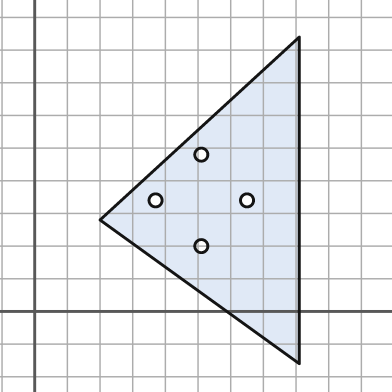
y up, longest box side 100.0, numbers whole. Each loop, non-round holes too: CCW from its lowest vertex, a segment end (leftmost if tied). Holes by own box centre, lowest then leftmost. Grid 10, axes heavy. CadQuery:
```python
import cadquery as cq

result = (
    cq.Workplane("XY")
    .moveTo(81.0, -16.0)
    .lineTo(81.0, 84.0)
    .lineTo(20.0, 28.0)
    .close()
    .moveTo(51.0, 20.0)
    .circle(2.0)
    .moveTo(37.0, 34.0)
    .circle(2.0)
    .moveTo(65.0, 34.0)
    .circle(2.0)
    .moveTo(51.0, 48.0)
    .circle(2.0)
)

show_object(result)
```